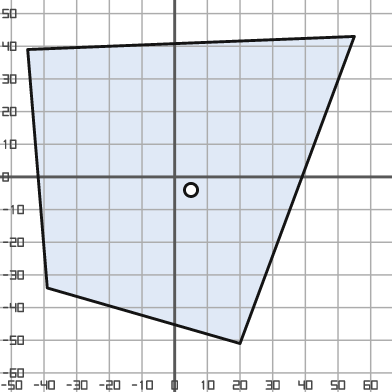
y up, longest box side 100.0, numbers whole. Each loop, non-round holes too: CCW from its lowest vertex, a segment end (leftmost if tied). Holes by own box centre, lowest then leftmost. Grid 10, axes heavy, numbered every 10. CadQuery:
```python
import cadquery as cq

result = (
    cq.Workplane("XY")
    .moveTo(20.0, -51.0)
    .lineTo(55.0, 43.0)
    .lineTo(-45.0, 39.0)
    .lineTo(-39.0, -34.0)
    .close()
    .moveTo(5.0, -4.0)
    .circle(2.0)
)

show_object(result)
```